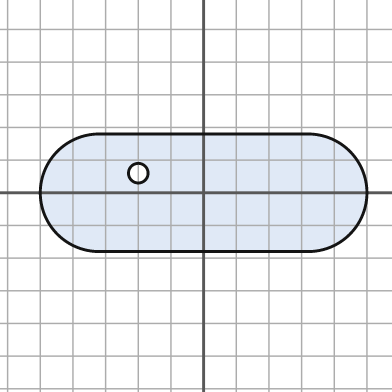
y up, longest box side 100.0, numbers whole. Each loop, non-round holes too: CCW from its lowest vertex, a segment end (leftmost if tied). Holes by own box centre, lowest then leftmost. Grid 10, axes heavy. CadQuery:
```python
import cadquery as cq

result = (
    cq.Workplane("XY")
    .moveTo(-32.0, -18.0)
    .lineTo(32.0, -18.0)
    .threePointArc((50.0, 0.0), (32.0, 18.0))
    .lineTo(-32.0, 18.0)
    .threePointArc((-50.0, 0.0), (-32.0, -18.0))
    .close()
    .moveTo(-20.0, 6.0)
    .circle(3.0)
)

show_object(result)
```